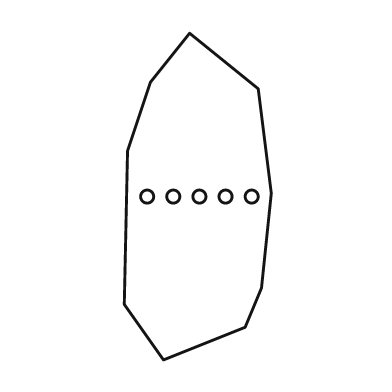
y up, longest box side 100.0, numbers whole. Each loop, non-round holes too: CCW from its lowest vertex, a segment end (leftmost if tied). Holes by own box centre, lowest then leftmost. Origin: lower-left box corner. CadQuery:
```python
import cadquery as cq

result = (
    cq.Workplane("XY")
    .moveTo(12.0, 0.0)
    .lineTo(37.0, 10.0)
    .lineTo(42.0, 22.0)
    .lineTo(45.0, 51.0)
    .lineTo(41.0, 83.0)
    .lineTo(20.0, 100.0)
    .lineTo(8.0, 85.0)
    .lineTo(1.0, 64.0)
    .lineTo(0.0, 17.0)
    .close()
    .moveTo(7.0, 50.0)
    .circle(2.0)
    .moveTo(15.0, 50.0)
    .circle(2.0)
    .moveTo(23.0, 50.0)
    .circle(2.0)
    .moveTo(31.0, 50.0)
    .circle(2.0)
    .moveTo(39.0, 50.0)
    .circle(2.0)
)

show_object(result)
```